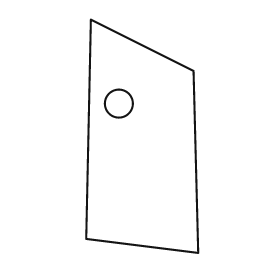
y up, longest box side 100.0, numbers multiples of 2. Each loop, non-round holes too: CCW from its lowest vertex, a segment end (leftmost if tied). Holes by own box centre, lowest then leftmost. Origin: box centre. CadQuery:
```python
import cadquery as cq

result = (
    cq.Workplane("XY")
    .moveTo(24.0, -50.0)
    .lineTo(22.0, 28.0)
    .lineTo(-22.0, 50.0)
    .lineTo(-24.0, -44.0)
    .close()
    .moveTo(-10.0, 14.0)
    .circle(6.0)
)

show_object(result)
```